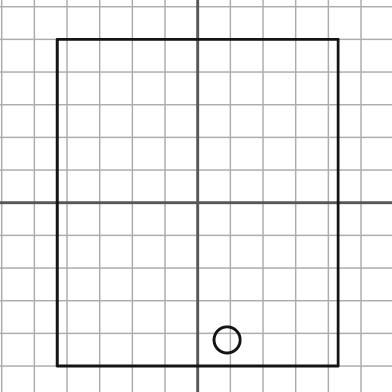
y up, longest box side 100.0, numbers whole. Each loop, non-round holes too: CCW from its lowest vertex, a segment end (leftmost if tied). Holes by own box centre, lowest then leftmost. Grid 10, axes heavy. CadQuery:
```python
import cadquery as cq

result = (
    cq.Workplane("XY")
    .moveTo(-43.0, -50.0)
    .lineTo(43.0, -50.0)
    .lineTo(43.0, 50.0)
    .lineTo(-43.0, 50.0)
    .close()
    .moveTo(9.0, -42.0)
    .circle(4.0)
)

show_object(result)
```